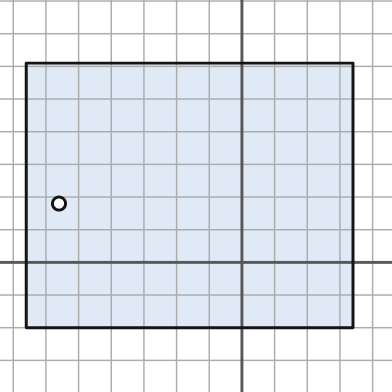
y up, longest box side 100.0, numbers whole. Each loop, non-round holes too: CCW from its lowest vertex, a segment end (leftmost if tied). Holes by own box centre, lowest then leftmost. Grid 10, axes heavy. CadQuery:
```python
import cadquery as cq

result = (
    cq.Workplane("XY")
    .moveTo(-66.0, -20.0)
    .lineTo(34.0, -20.0)
    .lineTo(34.0, 61.0)
    .lineTo(-66.0, 61.0)
    .close()
    .moveTo(-56.0, 18.0)
    .circle(2.0)
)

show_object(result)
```